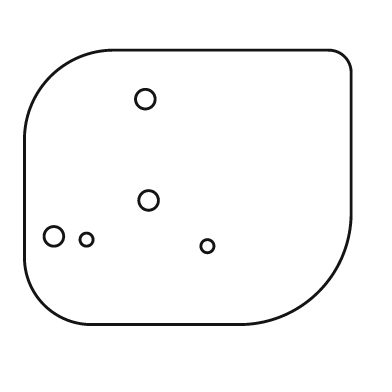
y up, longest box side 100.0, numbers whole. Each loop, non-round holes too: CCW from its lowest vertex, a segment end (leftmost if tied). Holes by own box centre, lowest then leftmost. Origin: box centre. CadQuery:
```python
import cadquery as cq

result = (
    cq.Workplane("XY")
    .moveTo(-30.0, -42.0)
    .lineTo(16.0, -42.0)
    .threePointArc((40.0, -32.0), (50.0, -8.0))
    .lineTo(50.0, 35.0)
    .threePointArc((48.0, 40.0), (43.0, 42.0))
    .lineTo(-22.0, 42.0)
    .threePointArc((-42.0, 34.0), (-50.0, 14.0))
    .lineTo(-50.0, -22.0)
    .threePointArc((-44.0, -36.0), (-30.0, -42.0))
    .close()
    .moveTo(6.0, -18.0)
    .circle(2.0)
    .moveTo(-31.0, -16.0)
    .circle(2.0)
    .moveTo(-41.0, -15.0)
    .circle(3.0)
    .moveTo(-12.0, -4.0)
    .circle(3.0)
    .moveTo(-13.0, 27.0)
    .circle(3.0)
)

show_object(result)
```